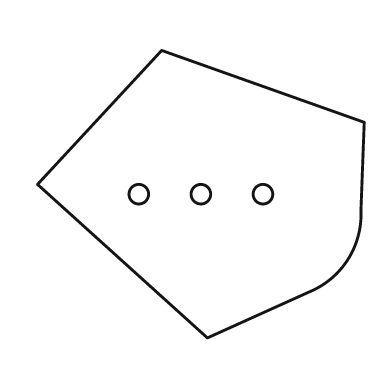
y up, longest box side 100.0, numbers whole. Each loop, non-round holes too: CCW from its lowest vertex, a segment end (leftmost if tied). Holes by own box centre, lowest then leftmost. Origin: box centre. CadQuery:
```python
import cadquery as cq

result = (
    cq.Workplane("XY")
    .moveTo(2.0, -44.0)
    .lineTo(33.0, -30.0)
    .threePointArc((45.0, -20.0), (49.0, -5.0))
    .lineTo(50.0, 22.0)
    .lineTo(-12.0, 44.0)
    .lineTo(-50.0, 3.0)
    .close()
    .moveTo(-19.0, 0.0)
    .circle(3.0)
    .moveTo(0.0, 0.0)
    .circle(3.0)
    .moveTo(19.0, 0.0)
    .circle(3.0)
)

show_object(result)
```